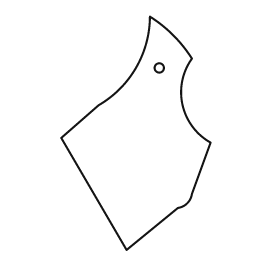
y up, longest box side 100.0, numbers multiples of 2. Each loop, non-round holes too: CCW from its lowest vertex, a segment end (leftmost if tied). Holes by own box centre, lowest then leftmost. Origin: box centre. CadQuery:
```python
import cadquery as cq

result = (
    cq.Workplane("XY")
    .moveTo(-4.0, -50.0)
    .lineTo(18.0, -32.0)
    .threePointArc((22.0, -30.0), (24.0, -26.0))
    .lineTo(32.0, -4.0)
    .threePointArc((20.0, 12.0), (24.0, 32.0))
    .threePointArc((16.0, 42.0), (6.0, 50.0))
    .threePointArc((0.0, 28.0), (-16.0, 12.0))
    .lineTo(-32.0, -2.0)
    .close()
    .moveTo(10.0, 28.0)
    .circle(2.0)
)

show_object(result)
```